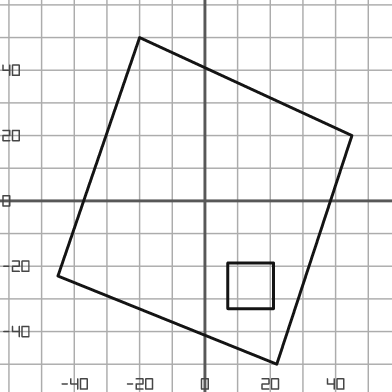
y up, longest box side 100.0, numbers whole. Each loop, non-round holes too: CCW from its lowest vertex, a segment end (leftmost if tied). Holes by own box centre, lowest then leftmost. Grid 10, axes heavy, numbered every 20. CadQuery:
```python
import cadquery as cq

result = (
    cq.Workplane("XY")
    .moveTo(22.0, -50.0)
    .lineTo(45.0, 20.0)
    .lineTo(-20.0, 50.0)
    .lineTo(-45.0, -23.0)
    .close()
    .moveTo(7.0, -33.0)
    .lineTo(21.0, -33.0)
    .lineTo(21.0, -19.0)
    .lineTo(7.0, -19.0)
    .close()
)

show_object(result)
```